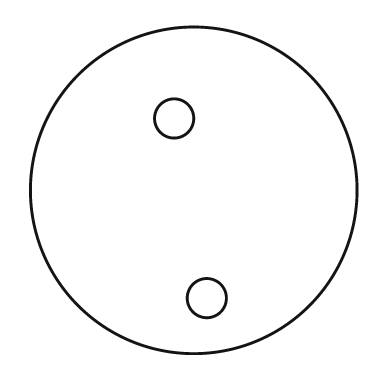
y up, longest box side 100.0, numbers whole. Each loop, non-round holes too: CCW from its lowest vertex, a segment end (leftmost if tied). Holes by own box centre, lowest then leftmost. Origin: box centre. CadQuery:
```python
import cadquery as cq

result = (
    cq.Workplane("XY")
    .moveTo(0.0, 0.0)
    .circle(50.0)
    .moveTo(4.0, -33.0)
    .circle(6.0)
    .moveTo(-6.0, 22.0)
    .circle(6.0)
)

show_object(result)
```